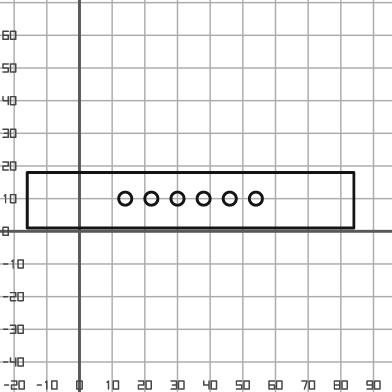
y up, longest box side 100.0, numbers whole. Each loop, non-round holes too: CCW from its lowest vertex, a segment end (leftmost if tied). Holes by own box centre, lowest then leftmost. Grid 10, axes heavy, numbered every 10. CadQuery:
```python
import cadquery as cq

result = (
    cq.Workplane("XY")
    .moveTo(-16.0, 1.0)
    .lineTo(84.0, 1.0)
    .lineTo(84.0, 18.0)
    .lineTo(-16.0, 18.0)
    .close()
    .moveTo(14.0, 10.0)
    .circle(2.0)
    .moveTo(22.0, 10.0)
    .circle(2.0)
    .moveTo(30.0, 10.0)
    .circle(2.0)
    .moveTo(38.0, 10.0)
    .circle(2.0)
    .moveTo(46.0, 10.0)
    .circle(2.0)
    .moveTo(54.0, 10.0)
    .circle(2.0)
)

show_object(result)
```